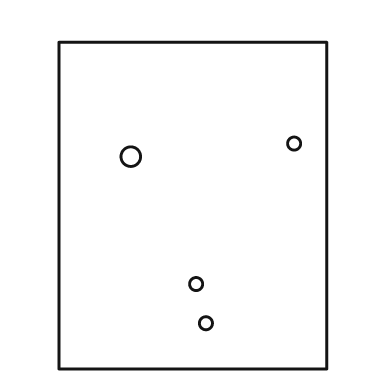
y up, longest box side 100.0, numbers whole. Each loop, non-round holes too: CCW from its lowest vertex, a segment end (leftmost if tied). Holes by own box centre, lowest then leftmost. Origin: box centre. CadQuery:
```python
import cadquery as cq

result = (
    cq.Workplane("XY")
    .moveTo(-41.0, -50.0)
    .lineTo(41.0, -50.0)
    .lineTo(41.0, 50.0)
    .lineTo(-41.0, 50.0)
    .close()
    .moveTo(4.0, -36.0)
    .circle(2.0)
    .moveTo(1.0, -24.0)
    .circle(2.0)
    .moveTo(-19.0, 15.0)
    .circle(3.0)
    .moveTo(31.0, 19.0)
    .circle(2.0)
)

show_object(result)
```